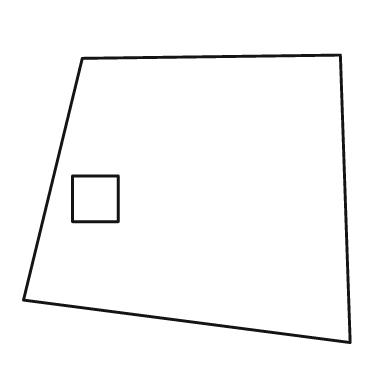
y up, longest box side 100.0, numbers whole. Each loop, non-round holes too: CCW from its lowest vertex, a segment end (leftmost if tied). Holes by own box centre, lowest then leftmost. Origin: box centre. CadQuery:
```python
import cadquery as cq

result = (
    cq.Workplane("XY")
    .moveTo(50.0, -44.0)
    .lineTo(47.0, 44.0)
    .lineTo(-32.0, 43.0)
    .lineTo(-50.0, -31.0)
    .close()
    .moveTo(-35.0, -7.0)
    .lineTo(-21.0, -7.0)
    .lineTo(-21.0, 7.0)
    .lineTo(-35.0, 7.0)
    .close()
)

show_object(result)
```